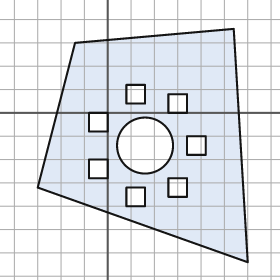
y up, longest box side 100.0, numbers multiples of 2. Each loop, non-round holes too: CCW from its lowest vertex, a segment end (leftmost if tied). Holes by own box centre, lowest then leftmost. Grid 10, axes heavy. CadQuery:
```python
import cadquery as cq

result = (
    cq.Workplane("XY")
    .moveTo(60.0, -64.0)
    .lineTo(54.0, 36.0)
    .lineTo(-14.0, 30.0)
    .lineTo(-30.0, -32.0)
    .close()
    .moveTo(8.0, -40.0)
    .lineTo(16.0, -40.0)
    .lineTo(16.0, -32.0)
    .lineTo(8.0, -32.0)
    .close()
    .moveTo(26.0, -36.0)
    .lineTo(34.0, -36.0)
    .lineTo(34.0, -28.0)
    .lineTo(26.0, -28.0)
    .close()
    .moveTo(-8.0, -28.0)
    .lineTo(0.0, -28.0)
    .lineTo(0.0, -20.0)
    .lineTo(-8.0, -20.0)
    .close()
    .moveTo(16.0, -14.0)
    .circle(12.0)
    .moveTo(34.0, -18.0)
    .lineTo(42.0, -18.0)
    .lineTo(42.0, -10.0)
    .lineTo(34.0, -10.0)
    .close()
    .moveTo(-8.0, -8.0)
    .lineTo(0.0, -8.0)
    .lineTo(0.0, 0.0)
    .lineTo(-8.0, 0.0)
    .close()
    .moveTo(26.0, 0.0)
    .lineTo(34.0, 0.0)
    .lineTo(34.0, 8.0)
    .lineTo(26.0, 8.0)
    .close()
    .moveTo(8.0, 4.0)
    .lineTo(16.0, 4.0)
    .lineTo(16.0, 12.0)
    .lineTo(8.0, 12.0)
    .close()
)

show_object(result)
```